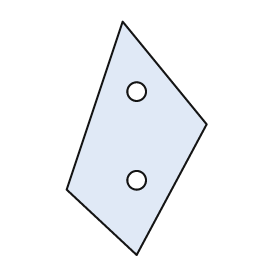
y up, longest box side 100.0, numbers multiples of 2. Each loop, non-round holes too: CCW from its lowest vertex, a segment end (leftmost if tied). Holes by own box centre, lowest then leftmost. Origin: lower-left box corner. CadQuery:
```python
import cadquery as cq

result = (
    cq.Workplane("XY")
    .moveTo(30.0, 0.0)
    .lineTo(60.0, 56.0)
    .lineTo(24.0, 100.0)
    .lineTo(0.0, 28.0)
    .close()
    .moveTo(30.0, 32.0)
    .circle(4.0)
    .moveTo(30.0, 70.0)
    .circle(4.0)
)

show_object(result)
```